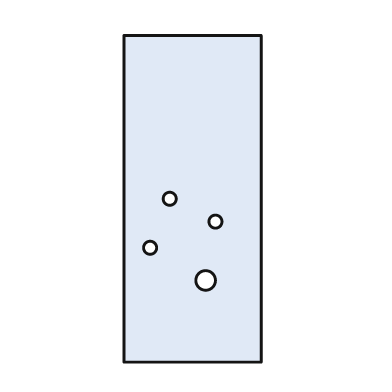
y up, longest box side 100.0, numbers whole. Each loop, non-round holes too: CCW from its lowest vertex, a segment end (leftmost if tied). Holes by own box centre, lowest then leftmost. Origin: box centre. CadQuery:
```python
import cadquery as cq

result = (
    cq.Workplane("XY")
    .moveTo(-21.0, -50.0)
    .lineTo(21.0, -50.0)
    .lineTo(21.0, 50.0)
    .lineTo(-21.0, 50.0)
    .close()
    .moveTo(4.0, -25.0)
    .circle(3.0)
    .moveTo(-13.0, -15.0)
    .circle(2.0)
    .moveTo(7.0, -7.0)
    .circle(2.0)
    .moveTo(-7.0, 0.0)
    .circle(2.0)
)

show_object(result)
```